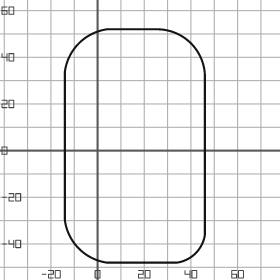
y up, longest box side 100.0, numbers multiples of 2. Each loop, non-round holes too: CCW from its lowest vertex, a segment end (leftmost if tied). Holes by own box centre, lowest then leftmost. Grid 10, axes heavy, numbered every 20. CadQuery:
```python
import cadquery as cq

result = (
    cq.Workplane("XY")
    .moveTo(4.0, -48.0)
    .lineTo(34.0, -48.0)
    .threePointArc((42.0, -44.0), (46.0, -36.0))
    .lineTo(46.0, 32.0)
    .threePointArc((40.0, 46.0), (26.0, 52.0))
    .lineTo(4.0, 52.0)
    .threePointArc((-8.0, 46.0), (-14.0, 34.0))
    .lineTo(-14.0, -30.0)
    .threePointArc((-8.0, -42.0), (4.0, -48.0))
    .close()
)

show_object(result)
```